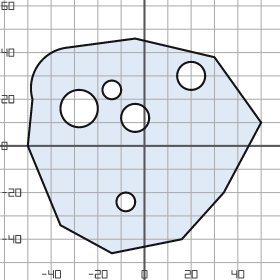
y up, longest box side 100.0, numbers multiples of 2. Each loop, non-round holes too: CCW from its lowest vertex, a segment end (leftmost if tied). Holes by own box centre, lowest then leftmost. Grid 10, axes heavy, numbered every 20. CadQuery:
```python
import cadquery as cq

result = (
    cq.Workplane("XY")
    .moveTo(-14.0, -46.0)
    .lineTo(16.0, -40.0)
    .lineTo(34.0, -20.0)
    .lineTo(50.0, 10.0)
    .lineTo(30.0, 38.0)
    .lineTo(-4.0, 46.0)
    .lineTo(-34.0, 42.0)
    .threePointArc((-46.0, 34.0), (-48.0, 20.0))
    .lineTo(-50.0, 0.0)
    .lineTo(-36.0, -34.0)
    .close()
    .moveTo(-8.0, -24.0)
    .circle(4.0)
    .moveTo(-4.0, 12.0)
    .circle(6.0)
    .moveTo(-28.0, 16.0)
    .circle(8.0)
    .moveTo(-14.0, 24.0)
    .circle(4.0)
    .moveTo(20.0, 30.0)
    .circle(6.0)
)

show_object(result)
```